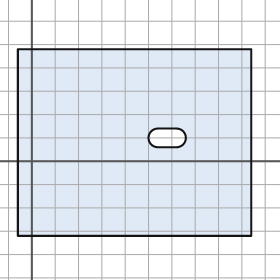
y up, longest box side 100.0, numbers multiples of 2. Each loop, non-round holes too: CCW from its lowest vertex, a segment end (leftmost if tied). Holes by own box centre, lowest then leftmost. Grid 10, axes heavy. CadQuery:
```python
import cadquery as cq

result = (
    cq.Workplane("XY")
    .moveTo(-6.0, -32.0)
    .lineTo(94.0, -32.0)
    .lineTo(94.0, 48.0)
    .lineTo(-6.0, 48.0)
    .close()
    .moveTo(54.0, 6.0)
    .lineTo(62.0, 6.0)
    .threePointArc((66.0, 10.0), (62.0, 14.0))
    .lineTo(54.0, 14.0)
    .threePointArc((50.0, 10.0), (54.0, 6.0))
    .close()
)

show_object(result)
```